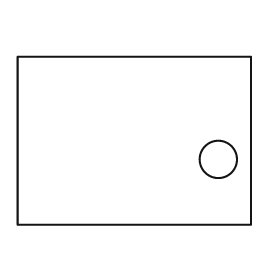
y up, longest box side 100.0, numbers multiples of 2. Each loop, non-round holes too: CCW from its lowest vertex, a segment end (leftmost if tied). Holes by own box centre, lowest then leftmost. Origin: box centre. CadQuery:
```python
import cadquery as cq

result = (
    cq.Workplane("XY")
    .moveTo(-50.0, -36.0)
    .lineTo(50.0, -36.0)
    .lineTo(50.0, 36.0)
    .lineTo(-50.0, 36.0)
    .close()
    .moveTo(36.0, -8.0)
    .circle(8.0)
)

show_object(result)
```